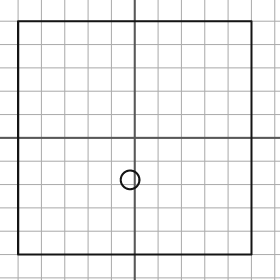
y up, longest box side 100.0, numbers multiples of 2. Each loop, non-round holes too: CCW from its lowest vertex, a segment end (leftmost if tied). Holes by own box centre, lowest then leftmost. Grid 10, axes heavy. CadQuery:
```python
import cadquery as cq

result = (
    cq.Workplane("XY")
    .moveTo(-50.0, -50.0)
    .lineTo(50.0, -50.0)
    .lineTo(50.0, 50.0)
    .lineTo(-50.0, 50.0)
    .close()
    .moveTo(-2.0, -18.0)
    .circle(4.0)
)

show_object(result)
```